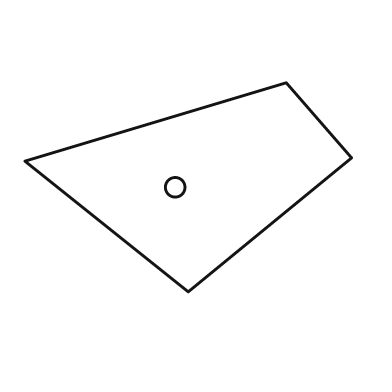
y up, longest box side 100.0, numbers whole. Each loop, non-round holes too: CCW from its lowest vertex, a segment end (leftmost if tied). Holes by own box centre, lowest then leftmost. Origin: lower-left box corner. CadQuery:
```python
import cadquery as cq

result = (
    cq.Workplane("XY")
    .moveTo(50.0, 0.0)
    .lineTo(100.0, 41.0)
    .lineTo(80.0, 64.0)
    .lineTo(0.0, 40.0)
    .close()
    .moveTo(46.0, 32.0)
    .circle(3.0)
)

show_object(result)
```